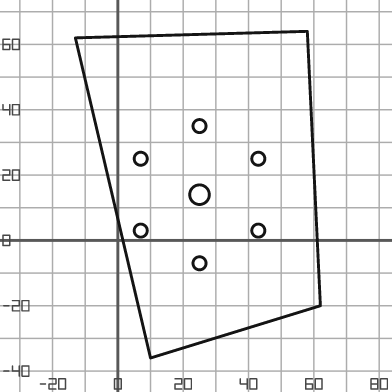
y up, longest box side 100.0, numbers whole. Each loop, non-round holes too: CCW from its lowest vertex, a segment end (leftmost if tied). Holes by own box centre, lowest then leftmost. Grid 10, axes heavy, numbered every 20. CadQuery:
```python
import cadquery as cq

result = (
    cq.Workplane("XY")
    .moveTo(10.0, -36.0)
    .lineTo(62.0, -20.0)
    .lineTo(58.0, 64.0)
    .lineTo(-13.0, 62.0)
    .close()
    .moveTo(25.0, -7.0)
    .circle(2.0)
    .moveTo(7.0, 3.0)
    .circle(2.0)
    .moveTo(43.0, 3.0)
    .circle(2.0)
    .moveTo(25.0, 14.0)
    .circle(3.0)
    .moveTo(7.0, 25.0)
    .circle(2.0)
    .moveTo(43.0, 25.0)
    .circle(2.0)
    .moveTo(25.0, 35.0)
    .circle(2.0)
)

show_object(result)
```